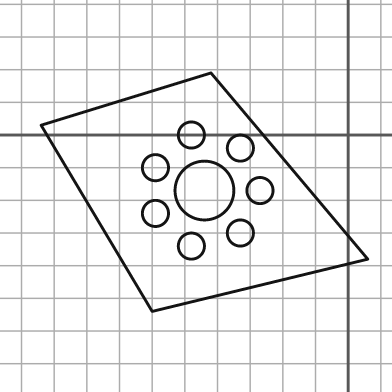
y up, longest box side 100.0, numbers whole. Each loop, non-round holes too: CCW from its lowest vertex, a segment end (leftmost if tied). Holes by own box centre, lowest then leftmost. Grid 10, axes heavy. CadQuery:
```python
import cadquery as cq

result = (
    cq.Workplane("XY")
    .moveTo(-60.0, -54.0)
    .lineTo(6.0, -38.0)
    .lineTo(-42.0, 19.0)
    .lineTo(-94.0, 3.0)
    .close()
    .moveTo(-48.0, -34.0)
    .circle(4.0)
    .moveTo(-33.0, -30.0)
    .circle(4.0)
    .moveTo(-59.0, -24.0)
    .circle(4.0)
    .moveTo(-44.0, -17.0)
    .circle(9.0)
    .moveTo(-27.0, -17.0)
    .circle(4.0)
    .moveTo(-59.0, -10.0)
    .circle(4.0)
    .moveTo(-33.0, -4.0)
    .circle(4.0)
    .moveTo(-48.0, 0.0)
    .circle(4.0)
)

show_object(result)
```